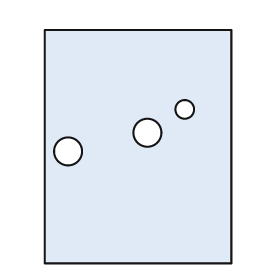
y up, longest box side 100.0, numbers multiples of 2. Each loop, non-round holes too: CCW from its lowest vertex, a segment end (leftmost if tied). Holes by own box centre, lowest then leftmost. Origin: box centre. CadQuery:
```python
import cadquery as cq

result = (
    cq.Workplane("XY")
    .moveTo(-40.0, -50.0)
    .lineTo(40.0, -50.0)
    .lineTo(40.0, 50.0)
    .lineTo(-40.0, 50.0)
    .close()
    .moveTo(-30.0, -2.0)
    .circle(6.0)
    .moveTo(4.0, 6.0)
    .circle(6.0)
    .moveTo(20.0, 16.0)
    .circle(4.0)
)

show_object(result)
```